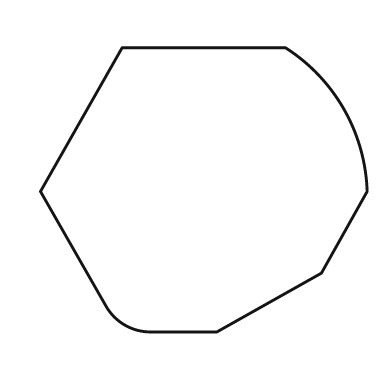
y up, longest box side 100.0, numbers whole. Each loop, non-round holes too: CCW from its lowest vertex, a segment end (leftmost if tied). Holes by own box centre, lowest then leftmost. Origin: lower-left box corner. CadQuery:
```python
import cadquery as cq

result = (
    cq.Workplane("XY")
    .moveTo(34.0, 0.0)
    .lineTo(54.0, 0.0)
    .lineTo(86.0, 18.0)
    .lineTo(100.0, 43.0)
    .threePointArc((93.0, 68.0), (75.0, 87.0))
    .lineTo(25.0, 87.0)
    .lineTo(0.0, 43.0)
    .lineTo(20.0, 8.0)
    .threePointArc((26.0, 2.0), (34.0, 0.0))
    .close()
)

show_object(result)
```